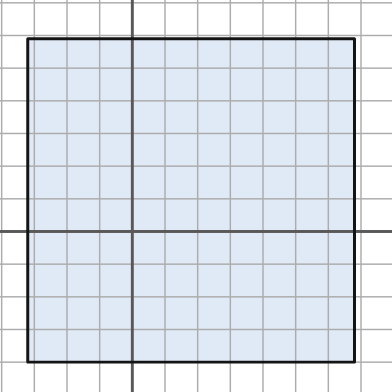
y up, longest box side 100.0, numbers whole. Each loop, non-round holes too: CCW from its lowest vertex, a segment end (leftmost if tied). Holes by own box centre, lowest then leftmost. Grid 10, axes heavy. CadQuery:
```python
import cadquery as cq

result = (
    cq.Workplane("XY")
    .moveTo(-32.0, -40.0)
    .lineTo(68.0, -40.0)
    .lineTo(68.0, 59.0)
    .lineTo(-32.0, 59.0)
    .close()
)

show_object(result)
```